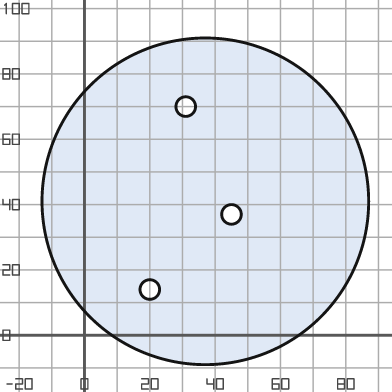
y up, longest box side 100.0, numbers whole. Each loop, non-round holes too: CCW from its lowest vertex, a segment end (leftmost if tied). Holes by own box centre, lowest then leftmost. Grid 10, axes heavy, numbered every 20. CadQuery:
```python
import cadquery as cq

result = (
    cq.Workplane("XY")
    .moveTo(37.0, 41.0)
    .circle(50.0)
    .moveTo(20.0, 14.0)
    .circle(3.0)
    .moveTo(45.0, 37.0)
    .circle(3.0)
    .moveTo(31.0, 70.0)
    .circle(3.0)
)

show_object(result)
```